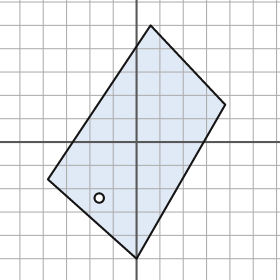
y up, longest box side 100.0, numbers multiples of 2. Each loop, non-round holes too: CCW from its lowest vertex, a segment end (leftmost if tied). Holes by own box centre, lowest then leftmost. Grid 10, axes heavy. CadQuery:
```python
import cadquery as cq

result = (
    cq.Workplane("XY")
    .moveTo(0.0, -50.0)
    .lineTo(38.0, 16.0)
    .lineTo(6.0, 50.0)
    .lineTo(-38.0, -16.0)
    .close()
    .moveTo(-16.0, -24.0)
    .circle(2.0)
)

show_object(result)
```